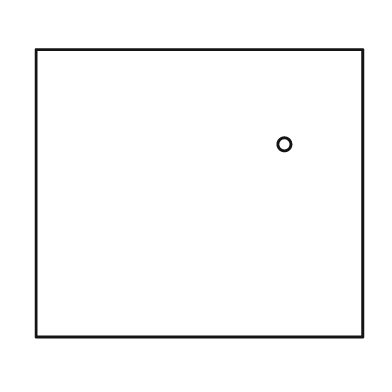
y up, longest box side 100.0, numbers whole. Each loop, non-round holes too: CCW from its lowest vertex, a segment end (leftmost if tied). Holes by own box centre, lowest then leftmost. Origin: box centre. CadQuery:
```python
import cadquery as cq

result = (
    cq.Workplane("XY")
    .moveTo(-50.0, -44.0)
    .lineTo(50.0, -44.0)
    .lineTo(50.0, 44.0)
    .lineTo(-50.0, 44.0)
    .close()
    .moveTo(26.0, 15.0)
    .circle(2.0)
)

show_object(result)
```